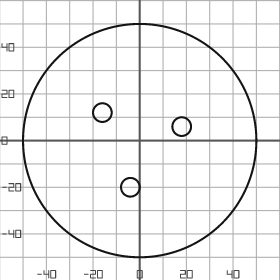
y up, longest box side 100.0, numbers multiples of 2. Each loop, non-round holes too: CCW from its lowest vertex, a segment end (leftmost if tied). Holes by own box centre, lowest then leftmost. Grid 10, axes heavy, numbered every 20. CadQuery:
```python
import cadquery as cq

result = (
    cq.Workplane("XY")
    .moveTo(0.0, 0.0)
    .circle(50.0)
    .moveTo(-4.0, -20.0)
    .circle(4.0)
    .moveTo(18.0, 6.0)
    .circle(4.0)
    .moveTo(-16.0, 12.0)
    .circle(4.0)
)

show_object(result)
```